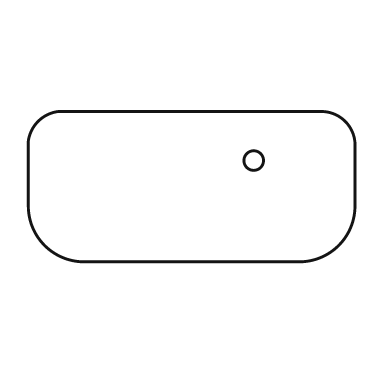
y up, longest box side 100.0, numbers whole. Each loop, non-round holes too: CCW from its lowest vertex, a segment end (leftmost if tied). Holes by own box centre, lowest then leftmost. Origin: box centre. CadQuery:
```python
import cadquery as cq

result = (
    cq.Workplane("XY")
    .moveTo(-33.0, -23.0)
    .lineTo(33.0, -23.0)
    .threePointArc((45.0, -18.0), (50.0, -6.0))
    .lineTo(50.0, 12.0)
    .threePointArc((47.0, 20.0), (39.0, 23.0))
    .lineTo(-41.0, 23.0)
    .threePointArc((-47.0, 20.0), (-50.0, 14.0))
    .lineTo(-50.0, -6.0)
    .threePointArc((-45.0, -18.0), (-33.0, -23.0))
    .close()
    .moveTo(19.0, 8.0)
    .circle(3.0)
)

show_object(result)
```